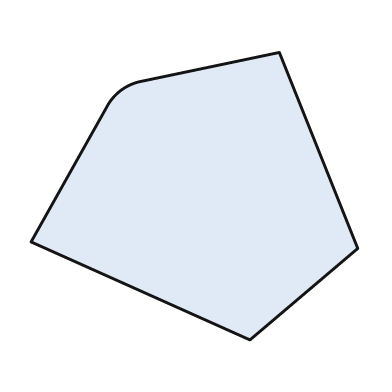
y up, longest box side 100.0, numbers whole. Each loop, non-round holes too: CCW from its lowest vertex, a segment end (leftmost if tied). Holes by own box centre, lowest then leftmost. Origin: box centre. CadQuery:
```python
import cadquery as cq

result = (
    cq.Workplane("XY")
    .moveTo(17.0, -44.0)
    .lineTo(50.0, -16.0)
    .lineTo(26.0, 44.0)
    .lineTo(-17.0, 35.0)
    .threePointArc((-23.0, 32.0), (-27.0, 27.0))
    .lineTo(-50.0, -14.0)
    .close()
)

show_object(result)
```